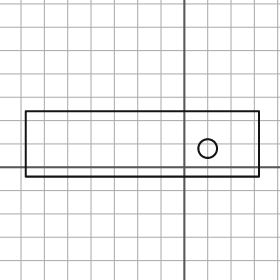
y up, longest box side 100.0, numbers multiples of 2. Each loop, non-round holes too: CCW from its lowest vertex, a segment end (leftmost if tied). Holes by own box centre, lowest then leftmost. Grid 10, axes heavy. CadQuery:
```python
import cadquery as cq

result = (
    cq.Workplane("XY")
    .moveTo(-68.0, -4.0)
    .lineTo(32.0, -4.0)
    .lineTo(32.0, 24.0)
    .lineTo(-68.0, 24.0)
    .close()
    .moveTo(10.0, 8.0)
    .circle(4.0)
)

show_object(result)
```